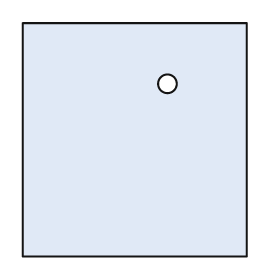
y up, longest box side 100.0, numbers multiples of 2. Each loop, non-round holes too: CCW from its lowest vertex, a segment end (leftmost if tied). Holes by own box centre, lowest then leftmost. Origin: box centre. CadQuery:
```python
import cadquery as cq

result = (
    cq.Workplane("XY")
    .moveTo(-48.0, -50.0)
    .lineTo(48.0, -50.0)
    .lineTo(48.0, 50.0)
    .lineTo(-48.0, 50.0)
    .close()
    .moveTo(14.0, 24.0)
    .circle(4.0)
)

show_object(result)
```